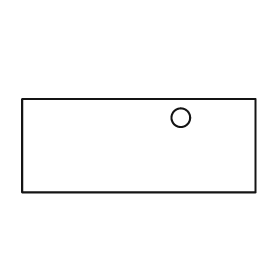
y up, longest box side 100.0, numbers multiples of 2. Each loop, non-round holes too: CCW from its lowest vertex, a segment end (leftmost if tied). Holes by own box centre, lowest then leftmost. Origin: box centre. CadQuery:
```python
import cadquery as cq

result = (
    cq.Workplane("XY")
    .moveTo(-50.0, -20.0)
    .lineTo(50.0, -20.0)
    .lineTo(50.0, 20.0)
    .lineTo(-50.0, 20.0)
    .close()
    .moveTo(18.0, 12.0)
    .circle(4.0)
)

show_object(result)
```